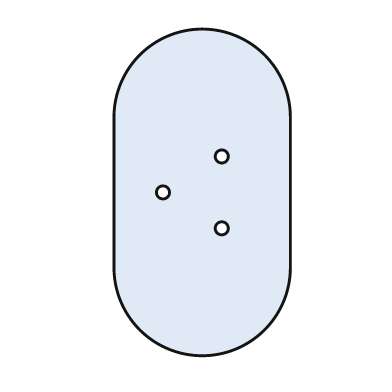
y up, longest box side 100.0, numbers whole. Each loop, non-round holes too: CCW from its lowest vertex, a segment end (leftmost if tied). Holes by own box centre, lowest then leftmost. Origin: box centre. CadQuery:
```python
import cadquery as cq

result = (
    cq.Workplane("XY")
    .moveTo(-27.0, -23.0)
    .threePointArc((0.0, -50.0), (27.0, -23.0))
    .lineTo(27.0, 23.0)
    .threePointArc((0.0, 50.0), (-27.0, 23.0))
    .close()
    .moveTo(6.0, -11.0)
    .circle(2.0)
    .moveTo(-12.0, 0.0)
    .circle(2.0)
    .moveTo(6.0, 11.0)
    .circle(2.0)
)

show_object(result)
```